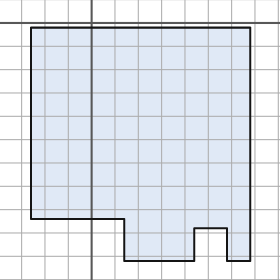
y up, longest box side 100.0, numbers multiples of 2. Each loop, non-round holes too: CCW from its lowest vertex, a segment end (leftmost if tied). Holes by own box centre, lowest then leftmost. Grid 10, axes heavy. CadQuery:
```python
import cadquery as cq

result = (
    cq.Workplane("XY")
    .moveTo(14.0, -102.0)
    .lineTo(44.0, -102.0)
    .lineTo(44.0, -88.0)
    .lineTo(58.0, -88.0)
    .lineTo(58.0, -102.0)
    .lineTo(68.0, -102.0)
    .lineTo(68.0, -2.0)
    .lineTo(-26.0, -2.0)
    .lineTo(-26.0, -84.0)
    .lineTo(14.0, -84.0)
    .close()
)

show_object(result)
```